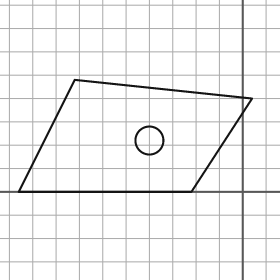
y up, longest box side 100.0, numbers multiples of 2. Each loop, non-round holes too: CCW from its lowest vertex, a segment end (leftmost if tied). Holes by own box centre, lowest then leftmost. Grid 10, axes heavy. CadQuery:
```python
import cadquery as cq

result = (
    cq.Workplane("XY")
    .moveTo(-96.0, 0.0)
    .lineTo(-22.0, 0.0)
    .lineTo(4.0, 40.0)
    .lineTo(-72.0, 48.0)
    .close()
    .moveTo(-40.0, 22.0)
    .circle(6.0)
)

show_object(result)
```